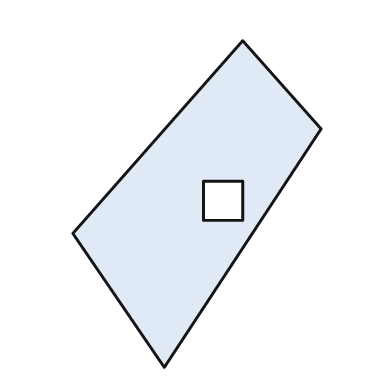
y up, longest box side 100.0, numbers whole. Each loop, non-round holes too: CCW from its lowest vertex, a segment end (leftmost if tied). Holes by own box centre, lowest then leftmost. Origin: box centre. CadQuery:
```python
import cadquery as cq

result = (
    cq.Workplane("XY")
    .moveTo(-10.0, -50.0)
    .lineTo(38.0, 23.0)
    .lineTo(14.0, 50.0)
    .lineTo(-38.0, -9.0)
    .close()
    .moveTo(2.0, -5.0)
    .lineTo(14.0, -5.0)
    .lineTo(14.0, 7.0)
    .lineTo(2.0, 7.0)
    .close()
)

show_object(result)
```